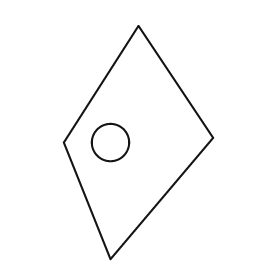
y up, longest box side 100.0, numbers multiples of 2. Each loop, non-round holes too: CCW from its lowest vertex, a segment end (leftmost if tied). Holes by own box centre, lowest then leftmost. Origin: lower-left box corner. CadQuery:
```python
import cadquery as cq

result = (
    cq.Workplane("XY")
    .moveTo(20.0, 0.0)
    .lineTo(64.0, 52.0)
    .lineTo(32.0, 100.0)
    .lineTo(0.0, 50.0)
    .close()
    .moveTo(20.0, 50.0)
    .circle(8.0)
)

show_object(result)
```